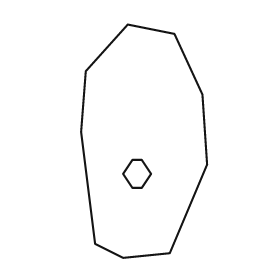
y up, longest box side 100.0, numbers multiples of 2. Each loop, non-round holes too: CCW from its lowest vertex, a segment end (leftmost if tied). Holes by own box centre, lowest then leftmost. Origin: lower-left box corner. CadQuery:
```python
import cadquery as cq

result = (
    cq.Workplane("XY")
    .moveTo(18.0, 0.0)
    .lineTo(38.0, 2.0)
    .lineTo(54.0, 40.0)
    .lineTo(52.0, 70.0)
    .lineTo(40.0, 96.0)
    .lineTo(20.0, 100.0)
    .lineTo(2.0, 80.0)
    .lineTo(0.0, 54.0)
    .lineTo(6.0, 6.0)
    .close()
    .moveTo(22.0, 30.0)
    .lineTo(26.0, 30.0)
    .lineTo(30.0, 36.0)
    .lineTo(26.0, 42.0)
    .lineTo(22.0, 42.0)
    .lineTo(18.0, 36.0)
    .close()
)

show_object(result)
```